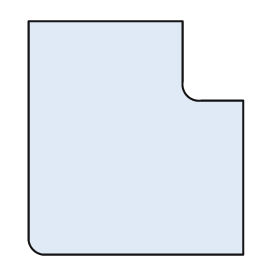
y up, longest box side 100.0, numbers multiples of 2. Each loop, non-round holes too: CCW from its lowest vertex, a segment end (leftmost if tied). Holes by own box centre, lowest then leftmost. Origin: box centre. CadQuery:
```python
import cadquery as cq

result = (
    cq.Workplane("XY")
    .moveTo(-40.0, -50.0)
    .lineTo(46.0, -50.0)
    .lineTo(46.0, 16.0)
    .lineTo(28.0, 16.0)
    .threePointArc((22.0, 18.0), (20.0, 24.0))
    .lineTo(20.0, 50.0)
    .lineTo(-46.0, 50.0)
    .lineTo(-46.0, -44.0)
    .threePointArc((-44.0, -48.0), (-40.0, -50.0))
    .close()
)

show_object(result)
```